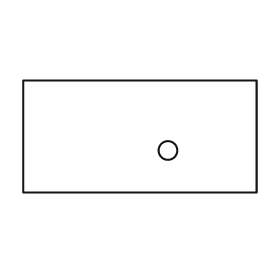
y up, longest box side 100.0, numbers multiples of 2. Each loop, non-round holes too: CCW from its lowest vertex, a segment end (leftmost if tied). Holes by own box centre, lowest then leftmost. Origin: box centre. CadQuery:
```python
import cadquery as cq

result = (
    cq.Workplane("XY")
    .moveTo(-50.0, -24.0)
    .lineTo(50.0, -24.0)
    .lineTo(50.0, 24.0)
    .lineTo(-50.0, 24.0)
    .close()
    .moveTo(12.0, -6.0)
    .circle(4.0)
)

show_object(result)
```